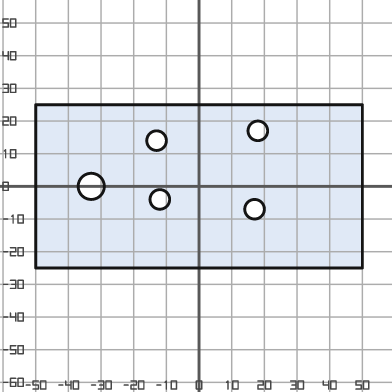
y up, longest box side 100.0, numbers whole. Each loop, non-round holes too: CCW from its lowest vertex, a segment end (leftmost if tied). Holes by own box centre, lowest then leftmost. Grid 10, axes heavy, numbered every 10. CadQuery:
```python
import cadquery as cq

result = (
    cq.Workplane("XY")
    .moveTo(-50.0, -25.0)
    .lineTo(50.0, -25.0)
    .lineTo(50.0, 25.0)
    .lineTo(-50.0, 25.0)
    .close()
    .moveTo(17.0, -7.0)
    .circle(3.0)
    .moveTo(-12.0, -4.0)
    .circle(3.0)
    .moveTo(-33.0, 0.0)
    .circle(4.0)
    .moveTo(-13.0, 14.0)
    .circle(3.0)
    .moveTo(18.0, 17.0)
    .circle(3.0)
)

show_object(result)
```